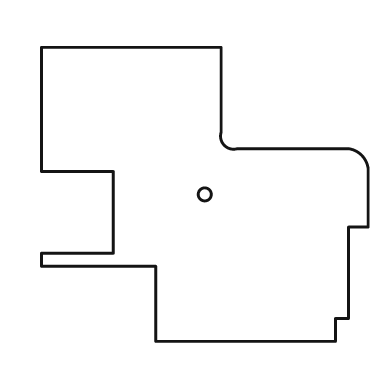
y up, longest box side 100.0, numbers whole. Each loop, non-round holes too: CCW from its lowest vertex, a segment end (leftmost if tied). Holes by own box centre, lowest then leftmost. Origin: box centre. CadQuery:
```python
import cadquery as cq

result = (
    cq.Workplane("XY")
    .moveTo(-15.0, -45.0)
    .lineTo(40.0, -45.0)
    .lineTo(40.0, -38.0)
    .lineTo(44.0, -38.0)
    .lineTo(44.0, -10.0)
    .lineTo(50.0, -10.0)
    .lineTo(50.0, 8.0)
    .threePointArc((48.0, 12.0), (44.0, 14.0))
    .lineTo(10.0, 14.0)
    .threePointArc((6.0, 15.0), (5.0, 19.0))
    .lineTo(5.0, 45.0)
    .lineTo(-50.0, 45.0)
    .lineTo(-50.0, 7.0)
    .lineTo(-28.0, 7.0)
    .lineTo(-28.0, -18.0)
    .lineTo(-50.0, -18.0)
    .lineTo(-50.0, -22.0)
    .lineTo(-15.0, -22.0)
    .close()
    .moveTo(0.0, 0.0)
    .circle(2.0)
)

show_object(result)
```